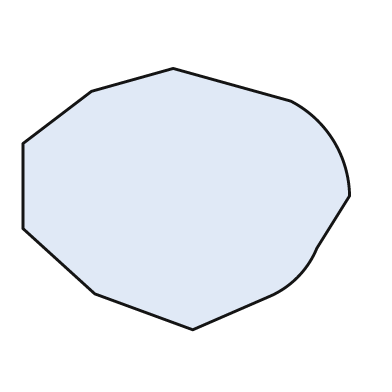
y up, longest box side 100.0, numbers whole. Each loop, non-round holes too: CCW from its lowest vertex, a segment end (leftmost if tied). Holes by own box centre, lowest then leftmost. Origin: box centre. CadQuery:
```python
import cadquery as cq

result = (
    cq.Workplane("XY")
    .moveTo(2.0, -40.0)
    .lineTo(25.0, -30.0)
    .threePointArc((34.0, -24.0), (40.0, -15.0))
    .lineTo(50.0, 1.0)
    .threePointArc((45.0, 18.0), (32.0, 30.0))
    .lineTo(-4.0, 40.0)
    .lineTo(-29.0, 33.0)
    .lineTo(-50.0, 17.0)
    .lineTo(-50.0, -9.0)
    .lineTo(-28.0, -29.0)
    .close()
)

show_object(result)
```